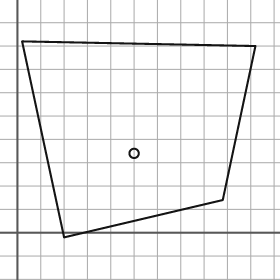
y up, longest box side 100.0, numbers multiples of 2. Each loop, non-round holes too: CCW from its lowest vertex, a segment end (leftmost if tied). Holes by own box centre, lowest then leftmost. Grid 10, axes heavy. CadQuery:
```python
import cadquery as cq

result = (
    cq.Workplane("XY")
    .moveTo(20.0, -2.0)
    .lineTo(88.0, 14.0)
    .lineTo(102.0, 80.0)
    .lineTo(2.0, 82.0)
    .close()
    .moveTo(50.0, 34.0)
    .circle(2.0)
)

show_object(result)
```